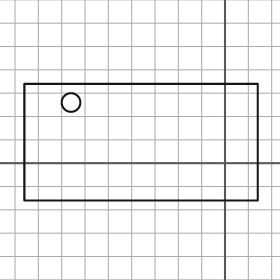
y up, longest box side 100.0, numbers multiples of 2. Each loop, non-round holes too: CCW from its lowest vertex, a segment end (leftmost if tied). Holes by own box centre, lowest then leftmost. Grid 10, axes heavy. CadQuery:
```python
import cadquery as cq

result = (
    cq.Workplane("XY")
    .moveTo(-86.0, -16.0)
    .lineTo(14.0, -16.0)
    .lineTo(14.0, 34.0)
    .lineTo(-86.0, 34.0)
    .close()
    .moveTo(-66.0, 26.0)
    .circle(4.0)
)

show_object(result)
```